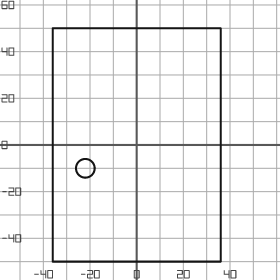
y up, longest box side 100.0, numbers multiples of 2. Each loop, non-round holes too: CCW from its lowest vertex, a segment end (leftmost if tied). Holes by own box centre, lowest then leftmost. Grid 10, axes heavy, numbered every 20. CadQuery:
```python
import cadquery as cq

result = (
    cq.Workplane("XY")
    .moveTo(-36.0, -50.0)
    .lineTo(36.0, -50.0)
    .lineTo(36.0, 50.0)
    .lineTo(-36.0, 50.0)
    .close()
    .moveTo(-22.0, -10.0)
    .circle(4.0)
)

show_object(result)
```